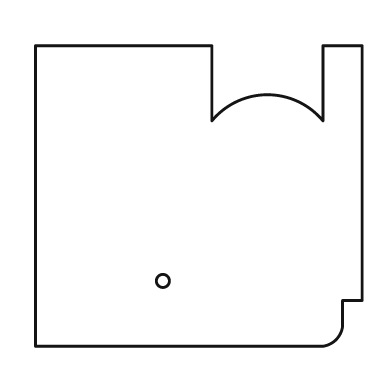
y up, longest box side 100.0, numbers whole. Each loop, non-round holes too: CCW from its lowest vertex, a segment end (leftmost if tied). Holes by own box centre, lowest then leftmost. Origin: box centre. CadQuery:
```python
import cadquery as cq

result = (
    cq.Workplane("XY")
    .moveTo(-50.0, -46.0)
    .lineTo(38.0, -46.0)
    .threePointArc((42.0, -44.0), (44.0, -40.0))
    .lineTo(44.0, -32.0)
    .lineTo(50.0, -32.0)
    .lineTo(50.0, 46.0)
    .lineTo(38.0, 46.0)
    .lineTo(38.0, 23.0)
    .threePointArc((21.0, 31.0), (4.0, 23.0))
    .lineTo(4.0, 46.0)
    .lineTo(-50.0, 46.0)
    .close()
    .moveTo(-11.0, -26.0)
    .circle(2.0)
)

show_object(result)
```